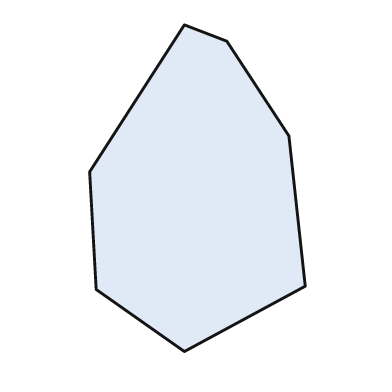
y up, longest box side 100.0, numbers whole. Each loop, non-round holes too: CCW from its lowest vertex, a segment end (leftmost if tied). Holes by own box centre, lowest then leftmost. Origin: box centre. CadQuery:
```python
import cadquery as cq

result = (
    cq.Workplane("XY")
    .moveTo(-4.0, -50.0)
    .lineTo(33.0, -30.0)
    .lineTo(28.0, 16.0)
    .lineTo(9.0, 45.0)
    .lineTo(-4.0, 50.0)
    .lineTo(-33.0, 5.0)
    .lineTo(-31.0, -31.0)
    .close()
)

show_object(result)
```